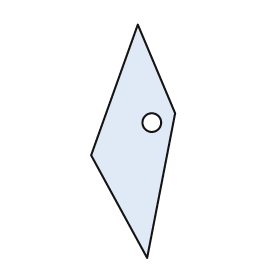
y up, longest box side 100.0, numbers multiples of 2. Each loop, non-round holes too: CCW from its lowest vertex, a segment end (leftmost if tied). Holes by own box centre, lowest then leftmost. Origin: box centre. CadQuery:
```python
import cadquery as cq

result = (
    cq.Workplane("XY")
    .moveTo(6.0, -50.0)
    .lineTo(18.0, 12.0)
    .lineTo(2.0, 50.0)
    .lineTo(-18.0, -6.0)
    .close()
    .moveTo(8.0, 8.0)
    .circle(4.0)
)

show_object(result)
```